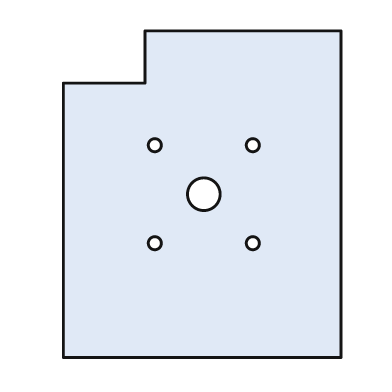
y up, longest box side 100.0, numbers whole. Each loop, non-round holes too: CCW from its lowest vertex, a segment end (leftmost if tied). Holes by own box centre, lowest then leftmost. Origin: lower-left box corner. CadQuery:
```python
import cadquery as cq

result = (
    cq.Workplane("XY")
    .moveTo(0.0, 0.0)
    .lineTo(85.0, 0.0)
    .lineTo(85.0, 100.0)
    .lineTo(25.0, 100.0)
    .lineTo(25.0, 84.0)
    .lineTo(0.0, 84.0)
    .close()
    .moveTo(28.0, 35.0)
    .circle(2.0)
    .moveTo(58.0, 35.0)
    .circle(2.0)
    .moveTo(43.0, 50.0)
    .circle(5.0)
    .moveTo(28.0, 65.0)
    .circle(2.0)
    .moveTo(58.0, 65.0)
    .circle(2.0)
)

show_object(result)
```